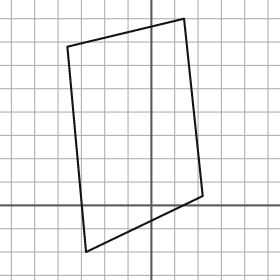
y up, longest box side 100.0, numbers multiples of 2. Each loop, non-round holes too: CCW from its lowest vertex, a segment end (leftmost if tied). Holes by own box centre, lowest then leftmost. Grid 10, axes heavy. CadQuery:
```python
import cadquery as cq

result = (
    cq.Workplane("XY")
    .moveTo(-28.0, -20.0)
    .lineTo(22.0, 4.0)
    .lineTo(14.0, 80.0)
    .lineTo(-36.0, 68.0)
    .close()
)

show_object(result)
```